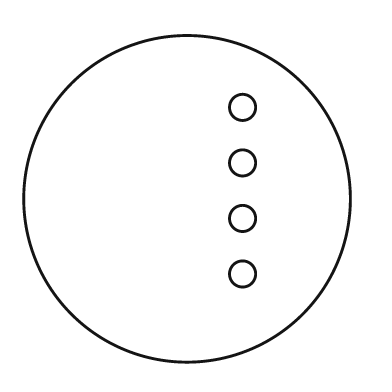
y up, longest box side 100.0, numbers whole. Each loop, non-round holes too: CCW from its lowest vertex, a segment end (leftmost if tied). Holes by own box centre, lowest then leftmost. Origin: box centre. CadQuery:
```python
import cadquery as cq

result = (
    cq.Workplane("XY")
    .moveTo(0.0, 0.0)
    .circle(50.0)
    .moveTo(17.0, -23.0)
    .circle(4.0)
    .moveTo(17.0, -6.0)
    .circle(4.0)
    .moveTo(17.0, 11.0)
    .circle(4.0)
    .moveTo(17.0, 28.0)
    .circle(4.0)
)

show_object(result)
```